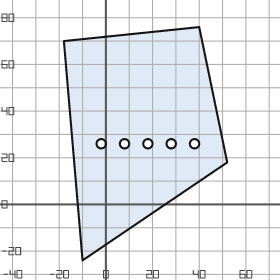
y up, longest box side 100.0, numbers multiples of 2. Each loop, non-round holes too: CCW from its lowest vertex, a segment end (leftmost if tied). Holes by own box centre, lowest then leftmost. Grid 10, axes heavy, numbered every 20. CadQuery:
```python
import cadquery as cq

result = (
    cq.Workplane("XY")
    .moveTo(-10.0, -24.0)
    .lineTo(52.0, 18.0)
    .lineTo(40.0, 76.0)
    .lineTo(-18.0, 70.0)
    .close()
    .moveTo(-2.0, 26.0)
    .circle(2.0)
    .moveTo(8.0, 26.0)
    .circle(2.0)
    .moveTo(18.0, 26.0)
    .circle(2.0)
    .moveTo(28.0, 26.0)
    .circle(2.0)
    .moveTo(38.0, 26.0)
    .circle(2.0)
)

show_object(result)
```